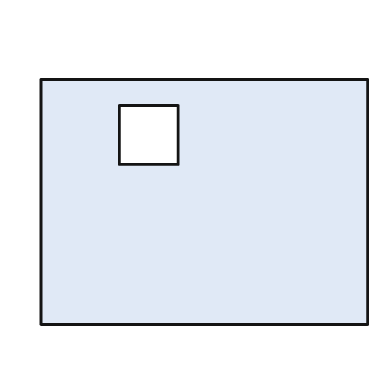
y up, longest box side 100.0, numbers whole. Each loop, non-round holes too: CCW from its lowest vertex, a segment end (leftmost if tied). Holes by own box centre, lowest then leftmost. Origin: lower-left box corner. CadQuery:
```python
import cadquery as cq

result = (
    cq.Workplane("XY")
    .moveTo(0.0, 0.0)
    .lineTo(100.0, 0.0)
    .lineTo(100.0, 75.0)
    .lineTo(0.0, 75.0)
    .close()
    .moveTo(24.0, 49.0)
    .lineTo(42.0, 49.0)
    .lineTo(42.0, 67.0)
    .lineTo(24.0, 67.0)
    .close()
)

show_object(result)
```